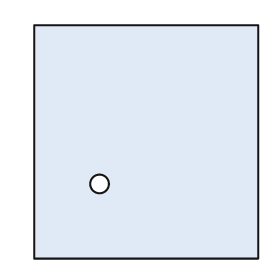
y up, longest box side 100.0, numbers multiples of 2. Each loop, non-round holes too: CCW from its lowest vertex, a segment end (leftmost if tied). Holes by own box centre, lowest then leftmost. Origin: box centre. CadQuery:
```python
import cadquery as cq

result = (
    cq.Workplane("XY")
    .moveTo(-48.0, -50.0)
    .lineTo(48.0, -50.0)
    .lineTo(48.0, 50.0)
    .lineTo(-48.0, 50.0)
    .close()
    .moveTo(-20.0, -18.0)
    .circle(4.0)
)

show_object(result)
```